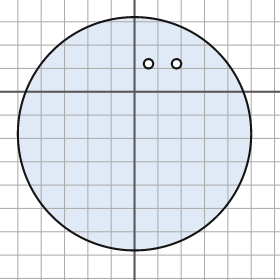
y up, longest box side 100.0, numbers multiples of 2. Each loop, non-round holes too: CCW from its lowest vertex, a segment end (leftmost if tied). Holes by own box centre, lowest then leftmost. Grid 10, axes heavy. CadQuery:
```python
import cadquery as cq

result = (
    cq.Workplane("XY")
    .moveTo(0.0, -18.0)
    .circle(50.0)
    .moveTo(6.0, 12.0)
    .circle(2.0)
    .moveTo(18.0, 12.0)
    .circle(2.0)
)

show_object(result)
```